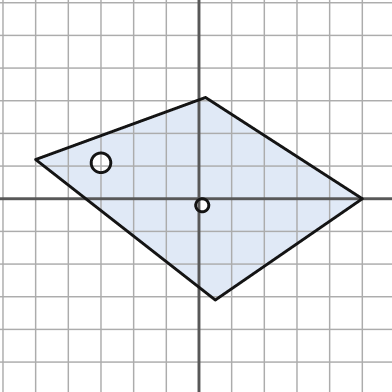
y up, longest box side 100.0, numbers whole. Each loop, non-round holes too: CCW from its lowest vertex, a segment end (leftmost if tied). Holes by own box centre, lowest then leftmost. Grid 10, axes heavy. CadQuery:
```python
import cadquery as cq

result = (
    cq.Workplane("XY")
    .moveTo(5.0, -31.0)
    .lineTo(50.0, 0.0)
    .lineTo(2.0, 31.0)
    .lineTo(-50.0, 12.0)
    .close()
    .moveTo(1.0, -2.0)
    .circle(2.0)
    .moveTo(-30.0, 11.0)
    .circle(3.0)
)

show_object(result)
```